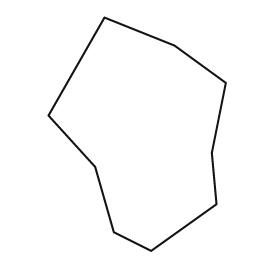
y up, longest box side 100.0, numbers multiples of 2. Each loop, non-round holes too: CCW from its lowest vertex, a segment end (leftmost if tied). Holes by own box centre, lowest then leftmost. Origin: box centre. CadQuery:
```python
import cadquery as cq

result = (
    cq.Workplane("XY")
    .moveTo(6.0, -50.0)
    .lineTo(34.0, -30.0)
    .lineTo(32.0, -8.0)
    .lineTo(38.0, 22.0)
    .lineTo(16.0, 38.0)
    .lineTo(-14.0, 50.0)
    .lineTo(-38.0, 8.0)
    .lineTo(-18.0, -14.0)
    .lineTo(-10.0, -42.0)
    .close()
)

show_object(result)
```